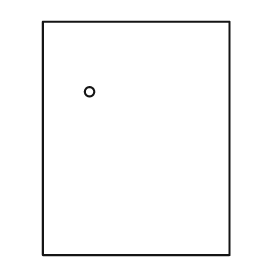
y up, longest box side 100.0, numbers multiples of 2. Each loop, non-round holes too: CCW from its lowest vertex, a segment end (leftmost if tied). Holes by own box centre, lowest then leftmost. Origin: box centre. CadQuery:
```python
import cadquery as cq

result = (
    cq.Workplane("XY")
    .moveTo(-40.0, -50.0)
    .lineTo(40.0, -50.0)
    .lineTo(40.0, 50.0)
    .lineTo(-40.0, 50.0)
    .close()
    .moveTo(-20.0, 20.0)
    .circle(2.0)
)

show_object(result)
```